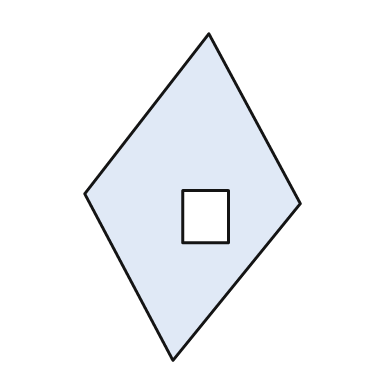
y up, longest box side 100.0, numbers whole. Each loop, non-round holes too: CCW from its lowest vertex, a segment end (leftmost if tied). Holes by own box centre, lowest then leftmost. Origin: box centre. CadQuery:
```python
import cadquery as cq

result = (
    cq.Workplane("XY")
    .moveTo(-6.0, -50.0)
    .lineTo(33.0, -2.0)
    .lineTo(5.0, 50.0)
    .lineTo(-33.0, 1.0)
    .close()
    .moveTo(-3.0, -14.0)
    .lineTo(11.0, -14.0)
    .lineTo(11.0, 2.0)
    .lineTo(-3.0, 2.0)
    .close()
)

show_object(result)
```